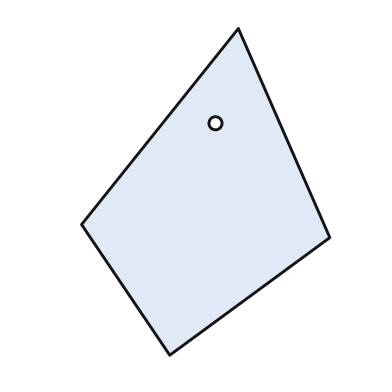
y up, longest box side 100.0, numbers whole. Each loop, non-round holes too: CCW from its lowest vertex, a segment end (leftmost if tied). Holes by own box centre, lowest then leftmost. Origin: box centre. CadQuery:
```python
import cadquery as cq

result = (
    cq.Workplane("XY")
    .moveTo(-11.0, -50.0)
    .lineTo(38.0, -14.0)
    .lineTo(10.0, 50.0)
    .lineTo(-38.0, -10.0)
    .close()
    .moveTo(3.0, 21.0)
    .circle(2.0)
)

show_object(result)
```